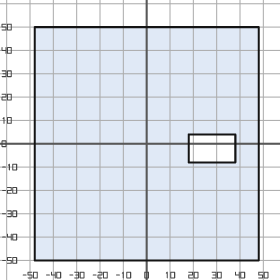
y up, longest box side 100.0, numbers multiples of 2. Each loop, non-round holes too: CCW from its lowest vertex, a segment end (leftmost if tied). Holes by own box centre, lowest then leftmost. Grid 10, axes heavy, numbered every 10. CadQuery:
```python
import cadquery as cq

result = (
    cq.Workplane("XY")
    .moveTo(-48.0, -50.0)
    .lineTo(48.0, -50.0)
    .lineTo(48.0, 50.0)
    .lineTo(-48.0, 50.0)
    .close()
    .moveTo(18.0, -8.0)
    .lineTo(38.0, -8.0)
    .lineTo(38.0, 4.0)
    .lineTo(18.0, 4.0)
    .close()
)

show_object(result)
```